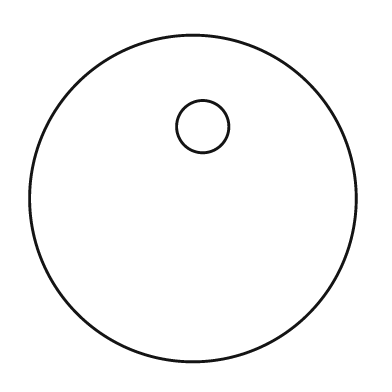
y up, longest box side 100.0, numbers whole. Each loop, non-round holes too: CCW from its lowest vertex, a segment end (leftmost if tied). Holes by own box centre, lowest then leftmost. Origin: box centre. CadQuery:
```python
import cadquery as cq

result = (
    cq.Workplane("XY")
    .moveTo(0.0, 0.0)
    .circle(50.0)
    .moveTo(3.0, 22.0)
    .circle(8.0)
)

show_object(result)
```